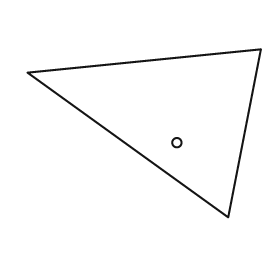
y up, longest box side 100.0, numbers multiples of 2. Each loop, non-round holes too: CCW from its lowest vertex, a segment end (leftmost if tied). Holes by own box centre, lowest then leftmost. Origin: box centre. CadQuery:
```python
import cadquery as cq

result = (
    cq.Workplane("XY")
    .moveTo(36.0, -36.0)
    .lineTo(50.0, 36.0)
    .lineTo(-50.0, 26.0)
    .close()
    .moveTo(14.0, -4.0)
    .circle(2.0)
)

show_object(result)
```